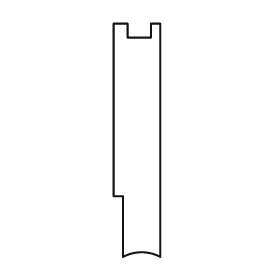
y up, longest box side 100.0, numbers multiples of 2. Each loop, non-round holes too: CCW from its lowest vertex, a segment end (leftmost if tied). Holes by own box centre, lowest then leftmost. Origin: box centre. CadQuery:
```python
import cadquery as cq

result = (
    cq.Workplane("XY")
    .moveTo(-6.0, -50.0)
    .threePointArc((2.0, -48.0), (10.0, -50.0))
    .lineTo(10.0, 50.0)
    .lineTo(6.0, 50.0)
    .lineTo(6.0, 44.0)
    .lineTo(-4.0, 44.0)
    .lineTo(-4.0, 50.0)
    .lineTo(-10.0, 50.0)
    .lineTo(-10.0, -24.0)
    .lineTo(-6.0, -24.0)
    .close()
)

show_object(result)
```